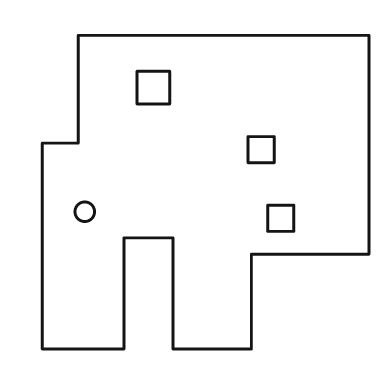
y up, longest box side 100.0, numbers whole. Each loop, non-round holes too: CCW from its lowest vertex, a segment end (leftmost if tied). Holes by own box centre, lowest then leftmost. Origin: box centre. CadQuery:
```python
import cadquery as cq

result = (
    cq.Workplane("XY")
    .moveTo(-50.0, -48.0)
    .lineTo(-25.0, -48.0)
    .lineTo(-25.0, -14.0)
    .lineTo(-10.0, -14.0)
    .lineTo(-10.0, -48.0)
    .lineTo(14.0, -48.0)
    .lineTo(14.0, -19.0)
    .lineTo(50.0, -19.0)
    .lineTo(50.0, 48.0)
    .lineTo(-39.0, 48.0)
    .lineTo(-39.0, 15.0)
    .lineTo(-50.0, 15.0)
    .close()
    .moveTo(19.0, -12.0)
    .lineTo(27.0, -12.0)
    .lineTo(27.0, -4.0)
    .lineTo(19.0, -4.0)
    .close()
    .moveTo(-37.0, -6.0)
    .circle(3.0)
    .moveTo(13.0, 9.0)
    .lineTo(21.0, 9.0)
    .lineTo(21.0, 17.0)
    .lineTo(13.0, 17.0)
    .close()
    .moveTo(-21.0, 27.0)
    .lineTo(-11.0, 27.0)
    .lineTo(-11.0, 37.0)
    .lineTo(-21.0, 37.0)
    .close()
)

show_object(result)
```